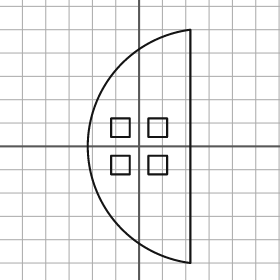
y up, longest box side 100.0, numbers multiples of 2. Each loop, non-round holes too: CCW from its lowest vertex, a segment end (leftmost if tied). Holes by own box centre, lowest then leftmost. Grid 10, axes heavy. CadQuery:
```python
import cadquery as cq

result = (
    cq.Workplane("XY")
    .moveTo(22.0, -50.0)
    .lineTo(22.0, 50.0)
    .threePointArc((-22.0, 0.0), (22.0, -50.0))
    .close()
    .moveTo(-12.0, -12.0)
    .lineTo(-4.0, -12.0)
    .lineTo(-4.0, -4.0)
    .lineTo(-12.0, -4.0)
    .close()
    .moveTo(4.0, -12.0)
    .lineTo(12.0, -12.0)
    .lineTo(12.0, -4.0)
    .lineTo(4.0, -4.0)
    .close()
    .moveTo(-12.0, 4.0)
    .lineTo(-4.0, 4.0)
    .lineTo(-4.0, 12.0)
    .lineTo(-12.0, 12.0)
    .close()
    .moveTo(4.0, 4.0)
    .lineTo(12.0, 4.0)
    .lineTo(12.0, 12.0)
    .lineTo(4.0, 12.0)
    .close()
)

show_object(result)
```